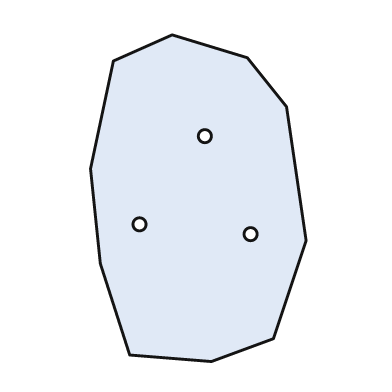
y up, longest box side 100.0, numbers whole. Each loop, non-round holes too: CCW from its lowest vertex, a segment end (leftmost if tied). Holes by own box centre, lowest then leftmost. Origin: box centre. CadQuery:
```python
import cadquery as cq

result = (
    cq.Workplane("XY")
    .moveTo(4.0, -50.0)
    .lineTo(23.0, -43.0)
    .lineTo(33.0, -13.0)
    .lineTo(27.0, 28.0)
    .lineTo(15.0, 43.0)
    .lineTo(-8.0, 50.0)
    .lineTo(-26.0, 42.0)
    .lineTo(-33.0, 9.0)
    .lineTo(-30.0, -20.0)
    .lineTo(-21.0, -48.0)
    .close()
    .moveTo(16.0, -11.0)
    .circle(2.0)
    .moveTo(-18.0, -8.0)
    .circle(2.0)
    .moveTo(2.0, 19.0)
    .circle(2.0)
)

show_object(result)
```